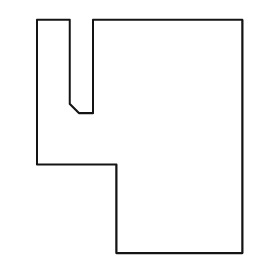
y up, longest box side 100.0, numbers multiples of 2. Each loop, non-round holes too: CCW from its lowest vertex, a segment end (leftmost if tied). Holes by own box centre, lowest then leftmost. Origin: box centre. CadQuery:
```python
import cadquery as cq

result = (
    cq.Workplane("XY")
    .moveTo(-10.0, -50.0)
    .lineTo(44.0, -50.0)
    .lineTo(44.0, 50.0)
    .lineTo(-20.0, 50.0)
    .lineTo(-20.0, 10.0)
    .lineTo(-26.0, 10.0)
    .lineTo(-30.0, 14.0)
    .lineTo(-30.0, 50.0)
    .lineTo(-44.0, 50.0)
    .lineTo(-44.0, -12.0)
    .lineTo(-10.0, -12.0)
    .close()
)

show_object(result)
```